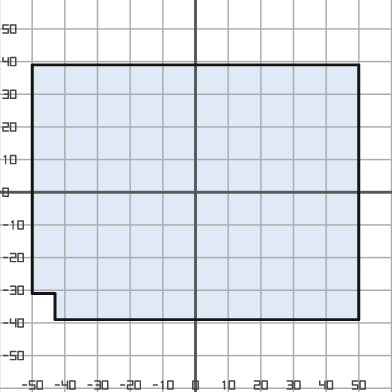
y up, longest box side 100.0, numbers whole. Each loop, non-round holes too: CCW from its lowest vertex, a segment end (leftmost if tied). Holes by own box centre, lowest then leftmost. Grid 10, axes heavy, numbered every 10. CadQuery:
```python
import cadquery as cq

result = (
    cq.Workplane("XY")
    .moveTo(-43.0, -39.0)
    .lineTo(50.0, -39.0)
    .lineTo(50.0, 39.0)
    .lineTo(-50.0, 39.0)
    .lineTo(-50.0, -31.0)
    .lineTo(-43.0, -31.0)
    .close()
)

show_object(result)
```